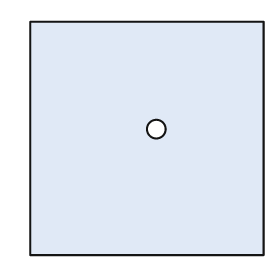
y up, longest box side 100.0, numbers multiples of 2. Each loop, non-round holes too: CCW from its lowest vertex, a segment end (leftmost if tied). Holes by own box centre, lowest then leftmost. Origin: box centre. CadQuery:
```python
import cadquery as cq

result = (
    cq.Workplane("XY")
    .moveTo(-50.0, -50.0)
    .lineTo(50.0, -50.0)
    .lineTo(50.0, 50.0)
    .lineTo(-50.0, 50.0)
    .close()
    .moveTo(4.0, 4.0)
    .circle(4.0)
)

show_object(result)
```